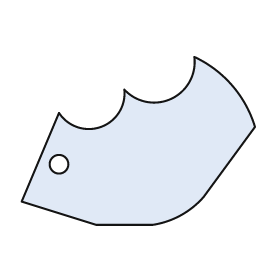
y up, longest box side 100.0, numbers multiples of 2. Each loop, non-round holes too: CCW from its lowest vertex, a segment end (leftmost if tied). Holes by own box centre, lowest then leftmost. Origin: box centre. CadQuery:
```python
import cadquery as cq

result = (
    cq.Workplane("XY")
    .moveTo(-18.0, -36.0)
    .lineTo(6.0, -36.0)
    .threePointArc((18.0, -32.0), (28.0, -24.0))
    .lineTo(50.0, 6.0)
    .threePointArc((40.0, 24.0), (24.0, 36.0))
    .threePointArc((14.0, 18.0), (-6.0, 22.0))
    .threePointArc((-16.0, 6.0), (-34.0, 12.0))
    .lineTo(-50.0, -26.0)
    .close()
    .moveTo(-34.0, -10.0)
    .circle(4.0)
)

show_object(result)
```